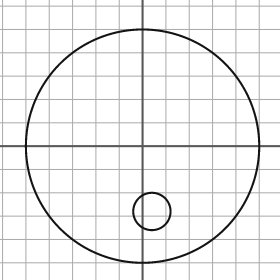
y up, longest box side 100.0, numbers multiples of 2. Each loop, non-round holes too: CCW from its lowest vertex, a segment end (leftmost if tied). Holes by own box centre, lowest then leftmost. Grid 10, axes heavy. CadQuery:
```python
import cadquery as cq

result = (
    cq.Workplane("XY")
    .moveTo(0.0, 0.0)
    .circle(50.0)
    .moveTo(4.0, -28.0)
    .circle(8.0)
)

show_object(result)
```